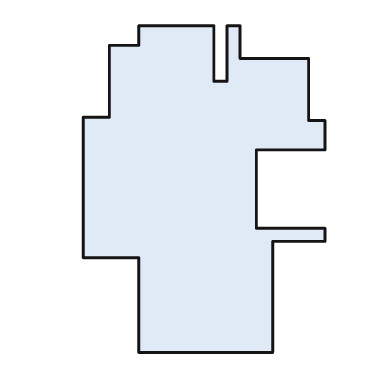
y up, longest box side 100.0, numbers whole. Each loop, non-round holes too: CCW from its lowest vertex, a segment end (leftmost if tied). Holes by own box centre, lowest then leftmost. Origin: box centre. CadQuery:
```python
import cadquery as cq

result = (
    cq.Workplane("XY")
    .moveTo(-20.0, -50.0)
    .lineTo(21.0, -50.0)
    .lineTo(21.0, -16.0)
    .lineTo(37.0, -16.0)
    .lineTo(37.0, -12.0)
    .lineTo(16.0, -12.0)
    .lineTo(16.0, 12.0)
    .lineTo(37.0, 12.0)
    .lineTo(37.0, 21.0)
    .lineTo(32.0, 21.0)
    .lineTo(32.0, 40.0)
    .lineTo(11.0, 40.0)
    .lineTo(11.0, 50.0)
    .lineTo(7.0, 50.0)
    .lineTo(7.0, 33.0)
    .lineTo(3.0, 33.0)
    .lineTo(3.0, 50.0)
    .lineTo(-20.0, 50.0)
    .lineTo(-20.0, 44.0)
    .lineTo(-29.0, 44.0)
    .lineTo(-29.0, 22.0)
    .lineTo(-37.0, 22.0)
    .lineTo(-37.0, -21.0)
    .lineTo(-20.0, -21.0)
    .close()
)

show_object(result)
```